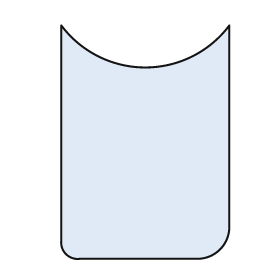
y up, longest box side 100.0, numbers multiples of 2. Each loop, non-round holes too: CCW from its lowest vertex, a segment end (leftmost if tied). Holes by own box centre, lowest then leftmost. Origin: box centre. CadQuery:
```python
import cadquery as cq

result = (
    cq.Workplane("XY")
    .moveTo(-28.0, -50.0)
    .lineTo(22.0, -50.0)
    .threePointArc((32.0, -46.0), (36.0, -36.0))
    .lineTo(36.0, 50.0)
    .threePointArc((0.0, 32.0), (-36.0, 50.0))
    .lineTo(-36.0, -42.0)
    .threePointArc((-34.0, -48.0), (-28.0, -50.0))
    .close()
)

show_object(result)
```